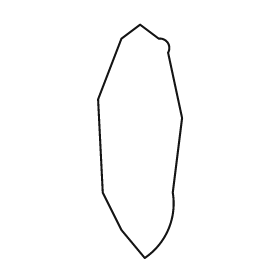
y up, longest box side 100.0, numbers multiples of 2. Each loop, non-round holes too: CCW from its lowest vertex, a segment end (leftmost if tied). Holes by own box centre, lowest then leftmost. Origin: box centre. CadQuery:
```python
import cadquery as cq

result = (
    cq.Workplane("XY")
    .moveTo(2.0, -50.0)
    .threePointArc((12.0, -38.0), (14.0, -22.0))
    .lineTo(18.0, 10.0)
    .lineTo(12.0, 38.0)
    .threePointArc((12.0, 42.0), (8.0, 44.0))
    .lineTo(0.0, 50.0)
    .lineTo(-8.0, 44.0)
    .lineTo(-18.0, 18.0)
    .lineTo(-16.0, -22.0)
    .lineTo(-8.0, -38.0)
    .close()
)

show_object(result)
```